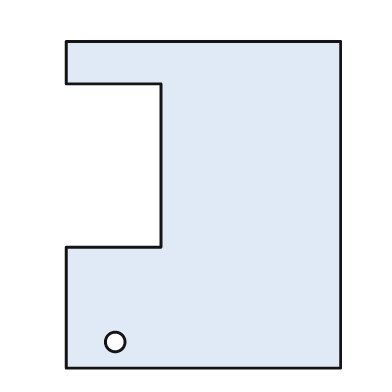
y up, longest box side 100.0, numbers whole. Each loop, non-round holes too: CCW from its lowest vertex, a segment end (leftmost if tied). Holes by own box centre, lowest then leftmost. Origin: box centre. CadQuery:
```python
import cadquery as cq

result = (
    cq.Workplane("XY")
    .moveTo(-42.0, -50.0)
    .lineTo(42.0, -50.0)
    .lineTo(42.0, 50.0)
    .lineTo(-42.0, 50.0)
    .lineTo(-42.0, 37.0)
    .lineTo(-13.0, 37.0)
    .lineTo(-13.0, -13.0)
    .lineTo(-42.0, -13.0)
    .close()
    .moveTo(-27.0, -42.0)
    .circle(3.0)
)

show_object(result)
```